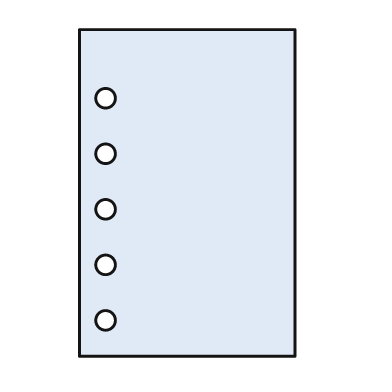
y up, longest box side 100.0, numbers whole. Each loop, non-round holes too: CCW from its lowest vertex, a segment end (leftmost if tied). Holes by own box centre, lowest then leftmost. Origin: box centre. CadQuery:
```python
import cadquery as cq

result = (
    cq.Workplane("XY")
    .moveTo(-33.0, -50.0)
    .lineTo(33.0, -50.0)
    .lineTo(33.0, 50.0)
    .lineTo(-33.0, 50.0)
    .close()
    .moveTo(-25.0, -39.0)
    .circle(3.0)
    .moveTo(-25.0, -22.0)
    .circle(3.0)
    .moveTo(-25.0, -5.0)
    .circle(3.0)
    .moveTo(-25.0, 12.0)
    .circle(3.0)
    .moveTo(-25.0, 29.0)
    .circle(3.0)
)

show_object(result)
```